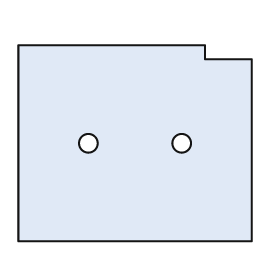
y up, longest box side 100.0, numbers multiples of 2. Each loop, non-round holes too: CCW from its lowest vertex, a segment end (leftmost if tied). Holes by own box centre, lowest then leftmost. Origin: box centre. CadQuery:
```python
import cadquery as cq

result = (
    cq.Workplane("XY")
    .moveTo(-50.0, -42.0)
    .lineTo(50.0, -42.0)
    .lineTo(50.0, 36.0)
    .lineTo(30.0, 36.0)
    .lineTo(30.0, 42.0)
    .lineTo(-50.0, 42.0)
    .close()
    .moveTo(-20.0, 0.0)
    .circle(4.0)
    .moveTo(20.0, 0.0)
    .circle(4.0)
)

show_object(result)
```